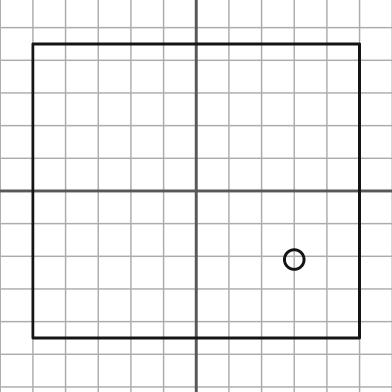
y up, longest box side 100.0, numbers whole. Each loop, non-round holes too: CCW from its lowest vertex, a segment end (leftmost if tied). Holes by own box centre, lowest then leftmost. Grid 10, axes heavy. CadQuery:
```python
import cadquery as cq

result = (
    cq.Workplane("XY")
    .moveTo(-50.0, -45.0)
    .lineTo(50.0, -45.0)
    .lineTo(50.0, 45.0)
    .lineTo(-50.0, 45.0)
    .close()
    .moveTo(30.0, -21.0)
    .circle(3.0)
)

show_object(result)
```